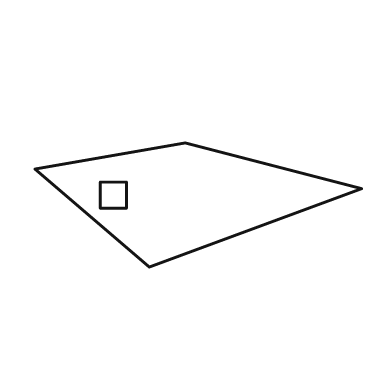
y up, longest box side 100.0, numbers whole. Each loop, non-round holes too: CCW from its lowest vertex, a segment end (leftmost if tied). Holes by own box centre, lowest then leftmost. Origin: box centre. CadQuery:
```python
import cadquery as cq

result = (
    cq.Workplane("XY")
    .moveTo(-15.0, -19.0)
    .lineTo(50.0, 5.0)
    .lineTo(-4.0, 19.0)
    .lineTo(-50.0, 11.0)
    .close()
    .moveTo(-30.0, -1.0)
    .lineTo(-22.0, -1.0)
    .lineTo(-22.0, 7.0)
    .lineTo(-30.0, 7.0)
    .close()
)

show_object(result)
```